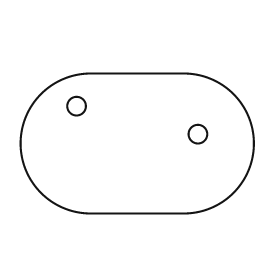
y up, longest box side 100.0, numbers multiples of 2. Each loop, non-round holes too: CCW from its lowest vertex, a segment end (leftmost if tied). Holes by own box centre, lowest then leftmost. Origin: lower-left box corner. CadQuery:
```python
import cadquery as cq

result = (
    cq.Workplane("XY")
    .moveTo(30.0, 0.0)
    .lineTo(70.0, 0.0)
    .threePointArc((100.0, 30.0), (70.0, 60.0))
    .lineTo(30.0, 60.0)
    .threePointArc((0.0, 30.0), (30.0, 0.0))
    .close()
    .moveTo(76.0, 34.0)
    .circle(4.0)
    .moveTo(24.0, 46.0)
    .circle(4.0)
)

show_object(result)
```